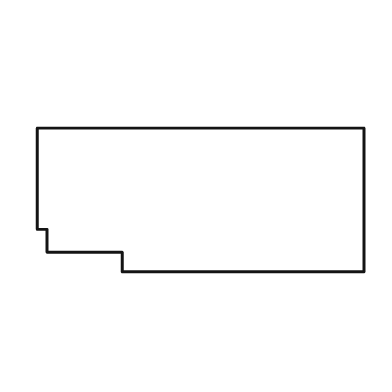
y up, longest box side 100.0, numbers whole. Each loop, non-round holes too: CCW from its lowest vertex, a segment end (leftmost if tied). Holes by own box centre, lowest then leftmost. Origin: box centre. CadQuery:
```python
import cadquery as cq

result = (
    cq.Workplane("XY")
    .moveTo(-24.0, -22.0)
    .lineTo(50.0, -22.0)
    .lineTo(50.0, 22.0)
    .lineTo(-50.0, 22.0)
    .lineTo(-50.0, -9.0)
    .lineTo(-47.0, -9.0)
    .lineTo(-47.0, -16.0)
    .lineTo(-24.0, -16.0)
    .close()
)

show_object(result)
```